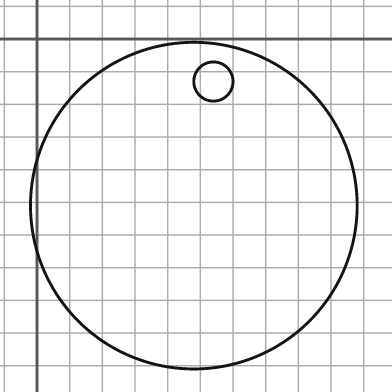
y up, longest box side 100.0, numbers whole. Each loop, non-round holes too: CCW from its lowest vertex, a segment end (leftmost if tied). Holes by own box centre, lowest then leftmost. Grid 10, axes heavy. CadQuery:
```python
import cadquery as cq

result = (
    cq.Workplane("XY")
    .moveTo(48.0, -51.0)
    .circle(50.0)
    .moveTo(54.0, -13.0)
    .circle(6.0)
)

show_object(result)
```